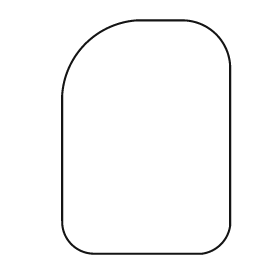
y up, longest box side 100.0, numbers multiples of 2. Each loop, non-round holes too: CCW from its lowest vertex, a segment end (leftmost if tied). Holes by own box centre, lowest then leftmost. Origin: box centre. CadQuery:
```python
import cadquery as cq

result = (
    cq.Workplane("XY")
    .moveTo(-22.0, -50.0)
    .lineTo(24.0, -50.0)
    .threePointArc((32.0, -46.0), (36.0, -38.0))
    .lineTo(36.0, 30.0)
    .threePointArc((30.0, 44.0), (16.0, 50.0))
    .lineTo(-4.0, 50.0)
    .threePointArc((-26.0, 40.0), (-36.0, 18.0))
    .lineTo(-36.0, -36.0)
    .threePointArc((-32.0, -46.0), (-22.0, -50.0))
    .close()
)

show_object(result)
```